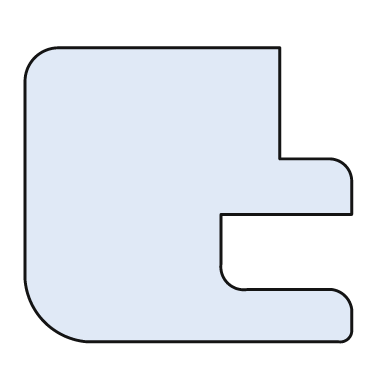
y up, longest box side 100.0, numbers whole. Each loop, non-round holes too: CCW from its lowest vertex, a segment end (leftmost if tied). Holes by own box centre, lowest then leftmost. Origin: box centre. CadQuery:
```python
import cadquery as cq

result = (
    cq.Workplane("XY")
    .moveTo(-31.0, -45.0)
    .lineTo(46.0, -45.0)
    .threePointArc((49.0, -44.0), (50.0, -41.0))
    .lineTo(50.0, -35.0)
    .threePointArc((48.0, -31.0), (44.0, -29.0))
    .lineTo(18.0, -29.0)
    .threePointArc((12.0, -27.0), (10.0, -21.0))
    .lineTo(10.0, -6.0)
    .lineTo(50.0, -6.0)
    .lineTo(50.0, 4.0)
    .threePointArc((48.0, 9.0), (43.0, 11.0))
    .lineTo(28.0, 11.0)
    .lineTo(28.0, 45.0)
    .lineTo(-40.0, 45.0)
    .threePointArc((-47.0, 42.0), (-50.0, 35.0))
    .lineTo(-50.0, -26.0)
    .threePointArc((-44.0, -39.0), (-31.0, -45.0))
    .close()
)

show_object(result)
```